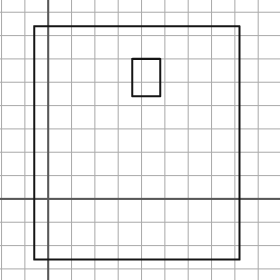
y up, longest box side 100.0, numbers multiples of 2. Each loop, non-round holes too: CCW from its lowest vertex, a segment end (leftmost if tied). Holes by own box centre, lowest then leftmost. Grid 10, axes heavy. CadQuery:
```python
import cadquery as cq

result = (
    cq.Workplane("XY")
    .moveTo(-6.0, -26.0)
    .lineTo(82.0, -26.0)
    .lineTo(82.0, 74.0)
    .lineTo(-6.0, 74.0)
    .close()
    .moveTo(36.0, 44.0)
    .lineTo(48.0, 44.0)
    .lineTo(48.0, 60.0)
    .lineTo(36.0, 60.0)
    .close()
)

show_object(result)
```